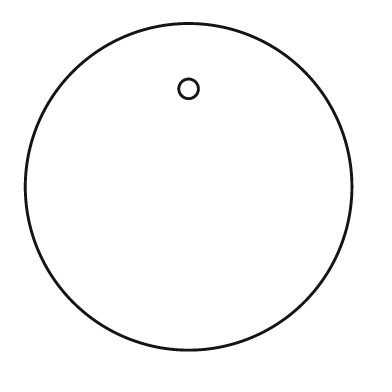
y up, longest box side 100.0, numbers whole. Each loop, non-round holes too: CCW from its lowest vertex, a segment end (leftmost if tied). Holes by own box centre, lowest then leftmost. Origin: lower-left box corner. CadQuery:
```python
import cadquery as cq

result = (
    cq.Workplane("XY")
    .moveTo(50.0, 50.0)
    .circle(50.0)
    .moveTo(50.0, 80.0)
    .circle(3.0)
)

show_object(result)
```